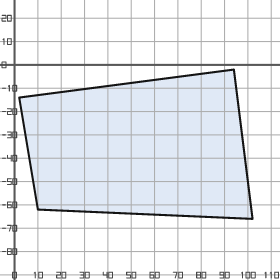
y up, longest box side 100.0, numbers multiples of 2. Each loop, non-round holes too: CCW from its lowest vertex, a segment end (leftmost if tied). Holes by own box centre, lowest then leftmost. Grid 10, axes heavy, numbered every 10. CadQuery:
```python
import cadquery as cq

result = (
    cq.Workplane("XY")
    .moveTo(102.0, -66.0)
    .lineTo(94.0, -2.0)
    .lineTo(2.0, -14.0)
    .lineTo(10.0, -62.0)
    .close()
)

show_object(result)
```